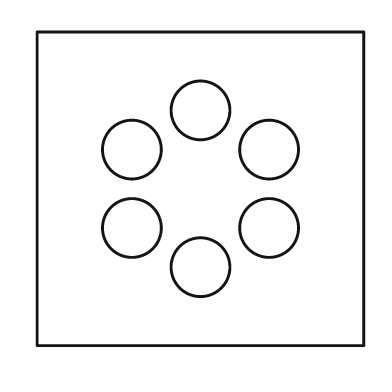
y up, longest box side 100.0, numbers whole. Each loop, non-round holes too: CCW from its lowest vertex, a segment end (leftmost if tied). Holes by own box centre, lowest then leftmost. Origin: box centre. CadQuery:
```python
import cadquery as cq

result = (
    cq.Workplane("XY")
    .moveTo(-50.0, -48.0)
    .lineTo(50.0, -48.0)
    .lineTo(50.0, 48.0)
    .lineTo(-50.0, 48.0)
    .close()
    .moveTo(0.0, -24.0)
    .circle(9.0)
    .moveTo(-21.0, -12.0)
    .circle(9.0)
    .moveTo(21.0, -12.0)
    .circle(9.0)
    .moveTo(-21.0, 12.0)
    .circle(9.0)
    .moveTo(21.0, 12.0)
    .circle(9.0)
    .moveTo(0.0, 24.0)
    .circle(9.0)
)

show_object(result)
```